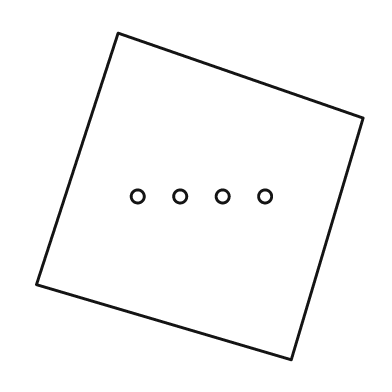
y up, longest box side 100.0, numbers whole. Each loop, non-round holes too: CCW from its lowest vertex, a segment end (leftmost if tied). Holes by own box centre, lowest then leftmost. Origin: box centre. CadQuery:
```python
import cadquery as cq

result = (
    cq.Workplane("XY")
    .moveTo(28.0, -50.0)
    .lineTo(50.0, 24.0)
    .lineTo(-25.0, 50.0)
    .lineTo(-50.0, -27.0)
    .close()
    .moveTo(-19.0, 0.0)
    .circle(2.0)
    .moveTo(-6.0, 0.0)
    .circle(2.0)
    .moveTo(7.0, 0.0)
    .circle(2.0)
    .moveTo(20.0, 0.0)
    .circle(2.0)
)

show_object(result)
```